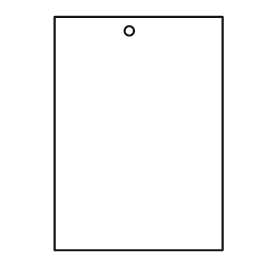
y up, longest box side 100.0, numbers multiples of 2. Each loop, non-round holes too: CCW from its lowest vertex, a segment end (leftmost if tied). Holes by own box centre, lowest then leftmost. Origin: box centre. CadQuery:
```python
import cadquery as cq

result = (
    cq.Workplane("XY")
    .moveTo(-36.0, -50.0)
    .lineTo(36.0, -50.0)
    .lineTo(36.0, 50.0)
    .lineTo(-36.0, 50.0)
    .close()
    .moveTo(-4.0, 44.0)
    .circle(2.0)
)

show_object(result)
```